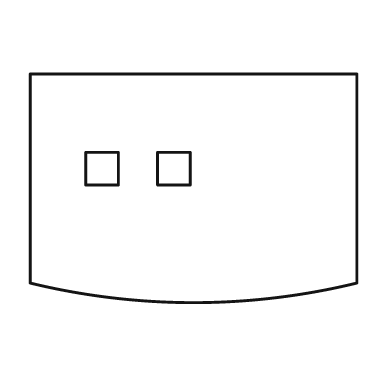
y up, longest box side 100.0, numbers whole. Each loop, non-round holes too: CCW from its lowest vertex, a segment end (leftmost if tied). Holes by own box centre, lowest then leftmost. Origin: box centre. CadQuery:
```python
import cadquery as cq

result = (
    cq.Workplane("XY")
    .moveTo(-50.0, -29.0)
    .threePointArc((0.0, -35.0), (50.0, -29.0))
    .lineTo(50.0, 35.0)
    .lineTo(-50.0, 35.0)
    .close()
    .moveTo(-33.0, 1.0)
    .lineTo(-23.0, 1.0)
    .lineTo(-23.0, 11.0)
    .lineTo(-33.0, 11.0)
    .close()
    .moveTo(-11.0, 1.0)
    .lineTo(-1.0, 1.0)
    .lineTo(-1.0, 11.0)
    .lineTo(-11.0, 11.0)
    .close()
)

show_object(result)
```